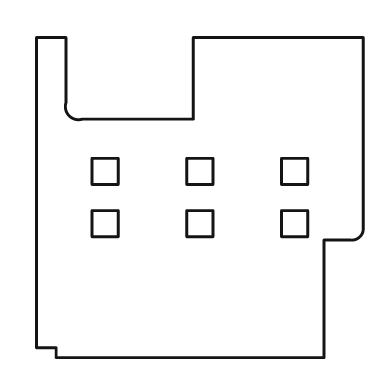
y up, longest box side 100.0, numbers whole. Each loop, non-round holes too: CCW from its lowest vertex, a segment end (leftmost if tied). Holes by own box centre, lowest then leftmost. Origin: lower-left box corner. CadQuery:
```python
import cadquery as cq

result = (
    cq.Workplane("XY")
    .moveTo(6.0, 0.0)
    .lineTo(88.0, 0.0)
    .lineTo(88.0, 36.0)
    .lineTo(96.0, 36.0)
    .threePointArc((99.0, 37.0), (100.0, 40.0))
    .lineTo(100.0, 98.0)
    .lineTo(48.0, 98.0)
    .lineTo(48.0, 73.0)
    .lineTo(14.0, 73.0)
    .threePointArc((10.0, 74.0), (9.0, 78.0))
    .lineTo(9.0, 98.0)
    .lineTo(0.0, 98.0)
    .lineTo(0.0, 3.0)
    .lineTo(6.0, 3.0)
    .close()
    .moveTo(17.0, 37.0)
    .lineTo(25.0, 37.0)
    .lineTo(25.0, 45.0)
    .lineTo(17.0, 45.0)
    .close()
    .moveTo(46.0, 37.0)
    .lineTo(54.0, 37.0)
    .lineTo(54.0, 45.0)
    .lineTo(46.0, 45.0)
    .close()
    .moveTo(75.0, 37.0)
    .lineTo(83.0, 37.0)
    .lineTo(83.0, 45.0)
    .lineTo(75.0, 45.0)
    .close()
    .moveTo(17.0, 53.0)
    .lineTo(25.0, 53.0)
    .lineTo(25.0, 61.0)
    .lineTo(17.0, 61.0)
    .close()
    .moveTo(46.0, 53.0)
    .lineTo(54.0, 53.0)
    .lineTo(54.0, 61.0)
    .lineTo(46.0, 61.0)
    .close()
    .moveTo(75.0, 53.0)
    .lineTo(83.0, 53.0)
    .lineTo(83.0, 61.0)
    .lineTo(75.0, 61.0)
    .close()
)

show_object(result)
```